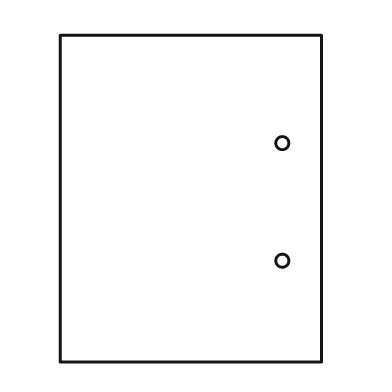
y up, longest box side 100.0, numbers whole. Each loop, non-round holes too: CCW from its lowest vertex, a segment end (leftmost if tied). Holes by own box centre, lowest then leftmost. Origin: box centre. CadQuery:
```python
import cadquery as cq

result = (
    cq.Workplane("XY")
    .moveTo(-40.0, -50.0)
    .lineTo(40.0, -50.0)
    .lineTo(40.0, 50.0)
    .lineTo(-40.0, 50.0)
    .close()
    .moveTo(28.0, -19.0)
    .circle(2.0)
    .moveTo(28.0, 17.0)
    .circle(2.0)
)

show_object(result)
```